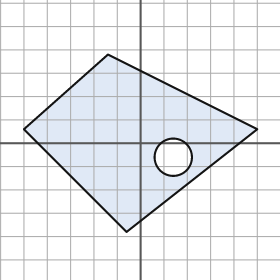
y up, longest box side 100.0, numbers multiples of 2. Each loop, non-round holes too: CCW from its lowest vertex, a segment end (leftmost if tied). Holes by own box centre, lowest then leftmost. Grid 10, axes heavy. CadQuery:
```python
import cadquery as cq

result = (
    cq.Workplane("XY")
    .moveTo(-6.0, -38.0)
    .lineTo(50.0, 6.0)
    .lineTo(-14.0, 38.0)
    .lineTo(-50.0, 6.0)
    .close()
    .moveTo(14.0, -6.0)
    .circle(8.0)
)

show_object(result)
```